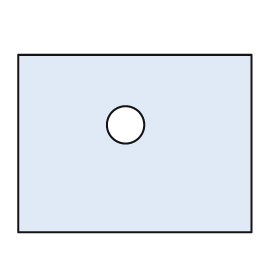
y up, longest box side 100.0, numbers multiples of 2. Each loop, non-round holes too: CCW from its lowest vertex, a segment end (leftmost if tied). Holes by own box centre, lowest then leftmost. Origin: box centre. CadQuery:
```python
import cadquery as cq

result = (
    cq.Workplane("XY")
    .moveTo(-50.0, -38.0)
    .lineTo(50.0, -38.0)
    .lineTo(50.0, 38.0)
    .lineTo(-50.0, 38.0)
    .close()
    .moveTo(-4.0, 8.0)
    .circle(8.0)
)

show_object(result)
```